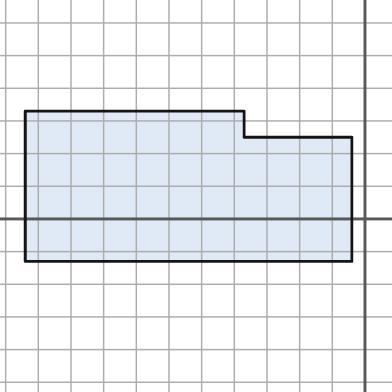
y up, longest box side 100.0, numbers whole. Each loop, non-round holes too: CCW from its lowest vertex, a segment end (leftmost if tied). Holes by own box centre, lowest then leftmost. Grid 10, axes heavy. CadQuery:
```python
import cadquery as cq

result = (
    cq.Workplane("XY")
    .moveTo(-104.0, -13.0)
    .lineTo(-4.0, -13.0)
    .lineTo(-4.0, 25.0)
    .lineTo(-37.0, 25.0)
    .lineTo(-37.0, 33.0)
    .lineTo(-104.0, 33.0)
    .close()
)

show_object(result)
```